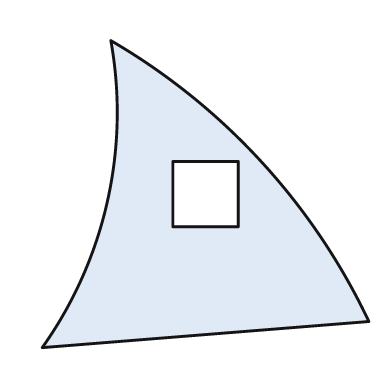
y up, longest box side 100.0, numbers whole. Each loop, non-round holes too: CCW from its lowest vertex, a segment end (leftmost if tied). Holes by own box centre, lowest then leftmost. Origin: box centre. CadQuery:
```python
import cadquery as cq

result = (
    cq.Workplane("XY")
    .moveTo(-50.0, -47.0)
    .lineTo(50.0, -39.0)
    .threePointArc((17.0, 10.0), (-29.0, 47.0))
    .threePointArc((-30.0, -2.0), (-50.0, -47.0))
    .close()
    .moveTo(-10.0, -10.0)
    .lineTo(10.0, -10.0)
    .lineTo(10.0, 10.0)
    .lineTo(-10.0, 10.0)
    .close()
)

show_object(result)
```